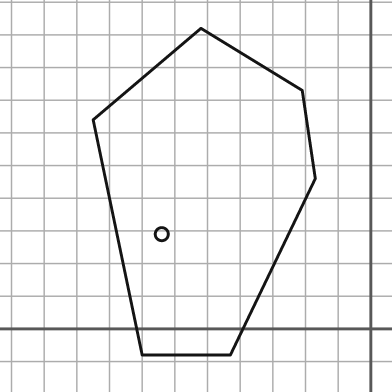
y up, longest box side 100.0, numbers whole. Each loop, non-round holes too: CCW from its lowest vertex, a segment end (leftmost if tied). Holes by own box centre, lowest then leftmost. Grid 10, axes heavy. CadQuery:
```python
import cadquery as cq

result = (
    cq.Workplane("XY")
    .moveTo(-70.0, -8.0)
    .lineTo(-43.0, -8.0)
    .lineTo(-17.0, 46.0)
    .lineTo(-21.0, 73.0)
    .lineTo(-52.0, 92.0)
    .lineTo(-85.0, 64.0)
    .close()
    .moveTo(-64.0, 29.0)
    .circle(2.0)
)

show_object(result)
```